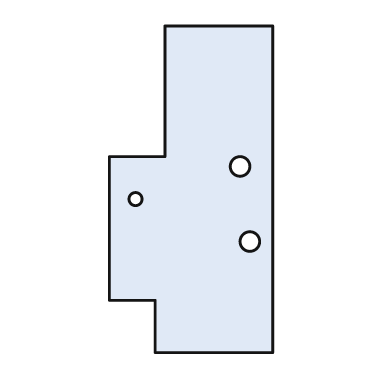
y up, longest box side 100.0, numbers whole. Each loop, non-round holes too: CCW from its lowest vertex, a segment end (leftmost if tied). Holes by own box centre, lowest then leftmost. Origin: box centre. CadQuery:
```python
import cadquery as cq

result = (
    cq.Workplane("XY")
    .moveTo(-11.0, -50.0)
    .lineTo(25.0, -50.0)
    .lineTo(25.0, 50.0)
    .lineTo(-8.0, 50.0)
    .lineTo(-8.0, 10.0)
    .lineTo(-25.0, 10.0)
    .lineTo(-25.0, -34.0)
    .lineTo(-11.0, -34.0)
    .close()
    .moveTo(18.0, -16.0)
    .circle(3.0)
    .moveTo(-17.0, -3.0)
    .circle(2.0)
    .moveTo(15.0, 7.0)
    .circle(3.0)
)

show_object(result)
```